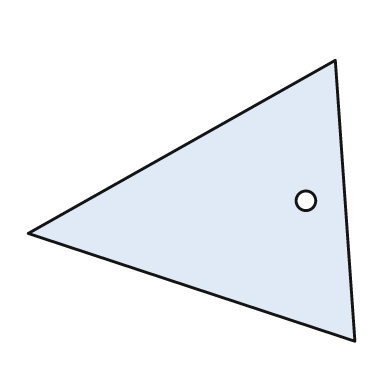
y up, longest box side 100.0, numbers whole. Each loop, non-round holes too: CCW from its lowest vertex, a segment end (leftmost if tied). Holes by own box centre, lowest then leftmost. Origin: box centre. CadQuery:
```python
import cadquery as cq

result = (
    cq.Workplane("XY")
    .moveTo(50.0, -43.0)
    .lineTo(44.0, 43.0)
    .lineTo(-50.0, -10.0)
    .close()
    .moveTo(35.0, 0.0)
    .circle(3.0)
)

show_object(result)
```